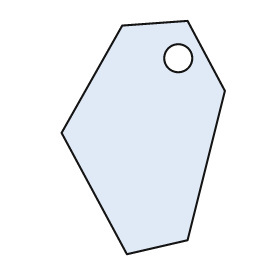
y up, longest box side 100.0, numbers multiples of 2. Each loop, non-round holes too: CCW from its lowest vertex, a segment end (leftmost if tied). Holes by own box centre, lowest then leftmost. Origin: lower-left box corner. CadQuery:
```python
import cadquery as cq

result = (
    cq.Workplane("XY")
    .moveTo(28.0, 0.0)
    .lineTo(54.0, 6.0)
    .lineTo(70.0, 70.0)
    .lineTo(54.0, 100.0)
    .lineTo(26.0, 98.0)
    .lineTo(0.0, 52.0)
    .close()
    .moveTo(50.0, 84.0)
    .circle(6.0)
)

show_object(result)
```